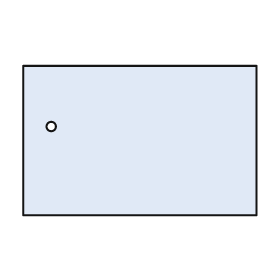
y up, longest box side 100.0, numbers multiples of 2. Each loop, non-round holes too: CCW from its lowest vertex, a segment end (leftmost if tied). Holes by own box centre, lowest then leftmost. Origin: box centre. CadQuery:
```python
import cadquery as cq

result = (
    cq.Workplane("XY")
    .moveTo(-50.0, -32.0)
    .lineTo(50.0, -32.0)
    .lineTo(50.0, 32.0)
    .lineTo(-50.0, 32.0)
    .close()
    .moveTo(-38.0, 6.0)
    .circle(2.0)
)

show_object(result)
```